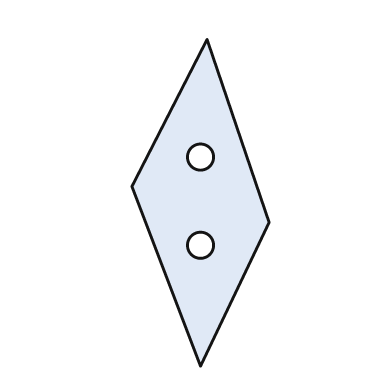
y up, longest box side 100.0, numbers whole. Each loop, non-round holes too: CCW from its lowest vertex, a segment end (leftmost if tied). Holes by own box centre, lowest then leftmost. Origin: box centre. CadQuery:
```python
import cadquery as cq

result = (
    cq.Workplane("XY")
    .moveTo(0.0, -50.0)
    .lineTo(21.0, -6.0)
    .lineTo(2.0, 50.0)
    .lineTo(-21.0, 5.0)
    .close()
    .moveTo(0.0, -13.0)
    .circle(4.0)
    .moveTo(0.0, 14.0)
    .circle(4.0)
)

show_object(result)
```